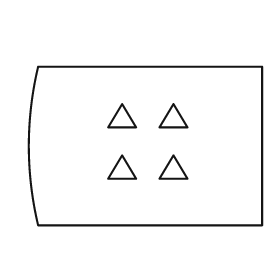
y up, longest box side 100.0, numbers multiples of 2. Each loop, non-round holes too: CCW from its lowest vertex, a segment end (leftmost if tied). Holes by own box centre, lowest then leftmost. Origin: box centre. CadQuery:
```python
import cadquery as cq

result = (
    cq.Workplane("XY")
    .moveTo(-46.0, -34.0)
    .lineTo(50.0, -34.0)
    .lineTo(50.0, 34.0)
    .lineTo(-46.0, 34.0)
    .threePointArc((-50.0, 0.0), (-46.0, -34.0))
    .close()
    .moveTo(-16.0, -14.0)
    .lineTo(-4.0, -14.0)
    .lineTo(-10.0, -4.0)
    .close()
    .moveTo(6.0, -14.0)
    .lineTo(18.0, -14.0)
    .lineTo(12.0, -4.0)
    .close()
    .moveTo(-16.0, 8.0)
    .lineTo(-4.0, 8.0)
    .lineTo(-10.0, 18.0)
    .close()
    .moveTo(6.0, 8.0)
    .lineTo(18.0, 8.0)
    .lineTo(12.0, 18.0)
    .close()
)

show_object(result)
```